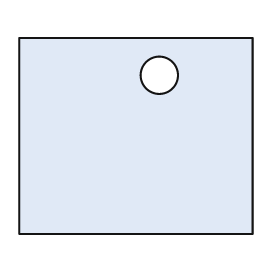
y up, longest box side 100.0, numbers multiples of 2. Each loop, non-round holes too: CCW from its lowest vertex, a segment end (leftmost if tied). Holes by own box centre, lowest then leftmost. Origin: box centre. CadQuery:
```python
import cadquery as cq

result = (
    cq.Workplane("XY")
    .moveTo(-50.0, -42.0)
    .lineTo(50.0, -42.0)
    .lineTo(50.0, 42.0)
    .lineTo(-50.0, 42.0)
    .close()
    .moveTo(10.0, 26.0)
    .circle(8.0)
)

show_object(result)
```